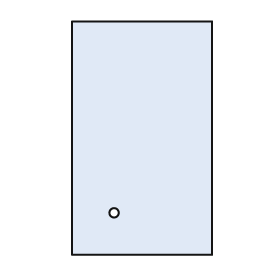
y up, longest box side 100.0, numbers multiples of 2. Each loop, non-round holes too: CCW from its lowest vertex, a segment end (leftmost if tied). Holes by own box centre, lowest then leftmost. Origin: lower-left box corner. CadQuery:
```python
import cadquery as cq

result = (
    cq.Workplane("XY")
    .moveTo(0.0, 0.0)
    .lineTo(60.0, 0.0)
    .lineTo(60.0, 100.0)
    .lineTo(0.0, 100.0)
    .close()
    .moveTo(18.0, 18.0)
    .circle(2.0)
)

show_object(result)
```